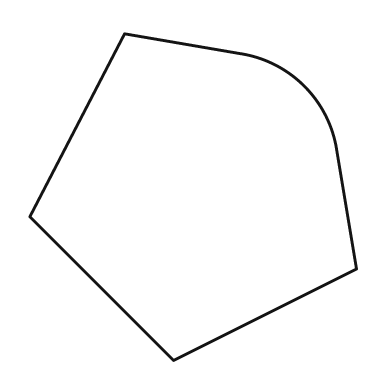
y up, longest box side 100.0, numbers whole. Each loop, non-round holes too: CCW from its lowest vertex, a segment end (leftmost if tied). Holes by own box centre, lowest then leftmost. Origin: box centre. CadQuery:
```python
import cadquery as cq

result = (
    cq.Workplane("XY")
    .moveTo(-6.0, -50.0)
    .lineTo(50.0, -22.0)
    .lineTo(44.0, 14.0)
    .threePointArc((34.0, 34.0), (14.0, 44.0))
    .lineTo(-21.0, 50.0)
    .lineTo(-50.0, -6.0)
    .close()
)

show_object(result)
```